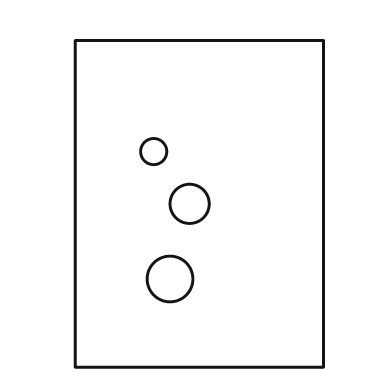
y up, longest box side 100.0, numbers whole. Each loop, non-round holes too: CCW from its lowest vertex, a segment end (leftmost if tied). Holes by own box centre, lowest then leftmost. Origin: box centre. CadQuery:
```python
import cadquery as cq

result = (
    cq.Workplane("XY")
    .moveTo(-38.0, -50.0)
    .lineTo(38.0, -50.0)
    .lineTo(38.0, 50.0)
    .lineTo(-38.0, 50.0)
    .close()
    .moveTo(-9.0, -23.0)
    .circle(7.0)
    .moveTo(-3.0, 0.0)
    .circle(6.0)
    .moveTo(-14.0, 16.0)
    .circle(4.0)
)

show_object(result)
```